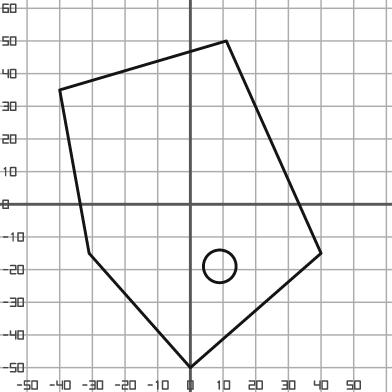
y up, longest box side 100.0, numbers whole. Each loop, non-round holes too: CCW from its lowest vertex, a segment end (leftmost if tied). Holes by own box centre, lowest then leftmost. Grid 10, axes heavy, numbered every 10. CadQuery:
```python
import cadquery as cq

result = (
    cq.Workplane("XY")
    .moveTo(0.0, -50.0)
    .lineTo(40.0, -15.0)
    .lineTo(11.0, 50.0)
    .lineTo(-40.0, 35.0)
    .lineTo(-31.0, -15.0)
    .close()
    .moveTo(9.0, -19.0)
    .circle(5.0)
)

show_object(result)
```